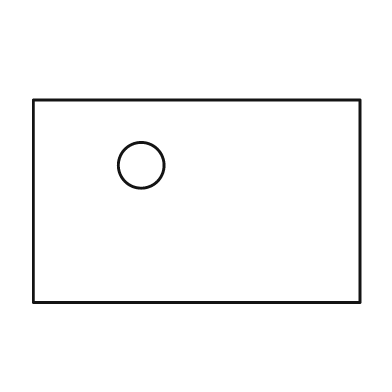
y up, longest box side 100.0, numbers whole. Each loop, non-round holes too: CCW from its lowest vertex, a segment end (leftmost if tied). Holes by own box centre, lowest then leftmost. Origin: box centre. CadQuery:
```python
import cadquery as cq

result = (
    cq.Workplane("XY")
    .moveTo(-50.0, -31.0)
    .lineTo(50.0, -31.0)
    .lineTo(50.0, 31.0)
    .lineTo(-50.0, 31.0)
    .close()
    .moveTo(-17.0, 11.0)
    .circle(7.0)
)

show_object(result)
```